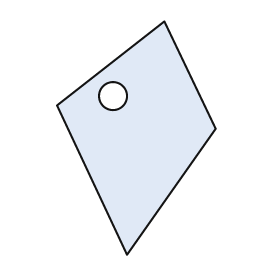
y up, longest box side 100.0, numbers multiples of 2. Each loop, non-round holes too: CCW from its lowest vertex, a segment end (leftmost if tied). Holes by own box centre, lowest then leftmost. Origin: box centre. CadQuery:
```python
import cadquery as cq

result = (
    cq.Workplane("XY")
    .moveTo(-4.0, -50.0)
    .lineTo(34.0, 4.0)
    .lineTo(12.0, 50.0)
    .lineTo(-34.0, 14.0)
    .close()
    .moveTo(-10.0, 18.0)
    .circle(6.0)
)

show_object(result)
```